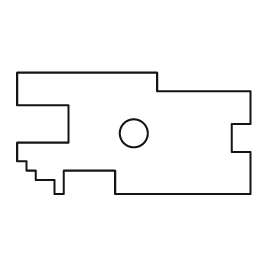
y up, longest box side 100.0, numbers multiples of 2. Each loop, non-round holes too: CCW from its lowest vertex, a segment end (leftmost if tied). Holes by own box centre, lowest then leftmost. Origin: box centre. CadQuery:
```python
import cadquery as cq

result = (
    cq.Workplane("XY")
    .moveTo(-34.0, -26.0)
    .lineTo(-30.0, -26.0)
    .lineTo(-30.0, -16.0)
    .lineTo(-8.0, -16.0)
    .lineTo(-8.0, -26.0)
    .lineTo(50.0, -26.0)
    .lineTo(50.0, -8.0)
    .lineTo(42.0, -8.0)
    .lineTo(42.0, 4.0)
    .lineTo(50.0, 4.0)
    .lineTo(50.0, 18.0)
    .lineTo(10.0, 18.0)
    .lineTo(10.0, 26.0)
    .lineTo(-50.0, 26.0)
    .lineTo(-50.0, 12.0)
    .lineTo(-28.0, 12.0)
    .lineTo(-28.0, -4.0)
    .lineTo(-50.0, -4.0)
    .lineTo(-50.0, -12.0)
    .lineTo(-46.0, -12.0)
    .lineTo(-46.0, -16.0)
    .lineTo(-42.0, -16.0)
    .lineTo(-42.0, -20.0)
    .lineTo(-34.0, -20.0)
    .close()
    .moveTo(0.0, 0.0)
    .circle(6.0)
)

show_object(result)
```